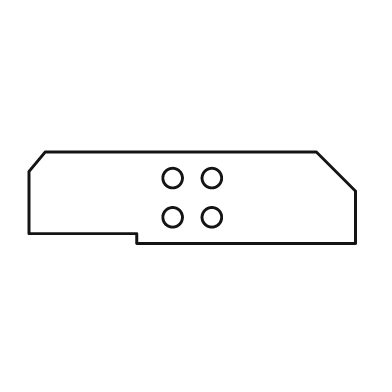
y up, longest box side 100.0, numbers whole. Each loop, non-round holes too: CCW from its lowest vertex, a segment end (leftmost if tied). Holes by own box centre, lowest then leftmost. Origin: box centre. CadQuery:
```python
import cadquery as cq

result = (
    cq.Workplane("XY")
    .moveTo(-17.0, -14.0)
    .lineTo(50.0, -14.0)
    .lineTo(50.0, 2.0)
    .lineTo(38.0, 14.0)
    .lineTo(-45.0, 14.0)
    .lineTo(-50.0, 8.0)
    .lineTo(-50.0, -11.0)
    .lineTo(-17.0, -11.0)
    .close()
    .moveTo(-6.0, -6.0)
    .circle(3.0)
    .moveTo(6.0, -6.0)
    .circle(3.0)
    .moveTo(-6.0, 6.0)
    .circle(3.0)
    .moveTo(6.0, 6.0)
    .circle(3.0)
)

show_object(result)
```